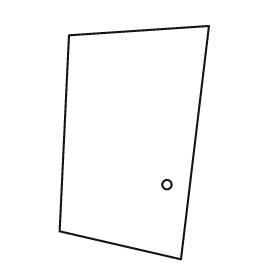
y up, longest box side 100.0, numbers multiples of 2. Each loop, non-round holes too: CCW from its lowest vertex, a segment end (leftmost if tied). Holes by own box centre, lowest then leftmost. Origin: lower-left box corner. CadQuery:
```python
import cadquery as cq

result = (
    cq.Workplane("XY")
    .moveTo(52.0, 0.0)
    .lineTo(64.0, 100.0)
    .lineTo(4.0, 96.0)
    .lineTo(0.0, 12.0)
    .close()
    .moveTo(46.0, 32.0)
    .circle(2.0)
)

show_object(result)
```